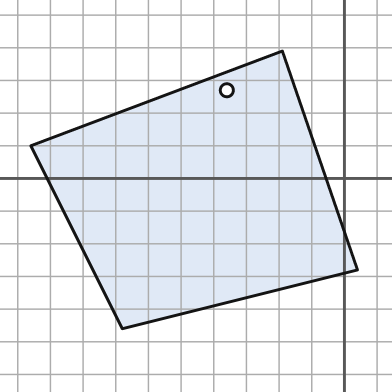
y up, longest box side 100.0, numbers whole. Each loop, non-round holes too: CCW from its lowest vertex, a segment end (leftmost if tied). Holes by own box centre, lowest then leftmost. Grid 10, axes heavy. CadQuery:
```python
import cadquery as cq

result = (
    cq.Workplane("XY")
    .moveTo(-68.0, -46.0)
    .lineTo(4.0, -28.0)
    .lineTo(-19.0, 39.0)
    .lineTo(-96.0, 10.0)
    .close()
    .moveTo(-36.0, 27.0)
    .circle(2.0)
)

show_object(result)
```